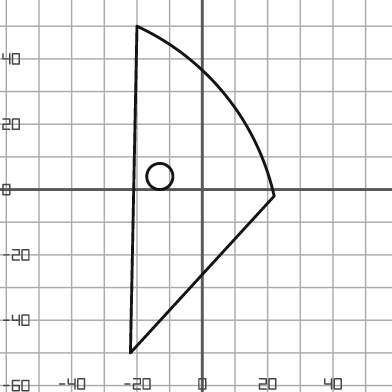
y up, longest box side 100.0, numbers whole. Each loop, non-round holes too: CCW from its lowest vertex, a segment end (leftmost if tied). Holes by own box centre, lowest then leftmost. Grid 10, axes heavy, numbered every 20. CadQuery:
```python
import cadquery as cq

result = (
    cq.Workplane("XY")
    .moveTo(-22.0, -50.0)
    .lineTo(22.0, -2.0)
    .threePointArc((7.0, 29.0), (-20.0, 50.0))
    .close()
    .moveTo(-13.0, 4.0)
    .circle(4.0)
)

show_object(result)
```